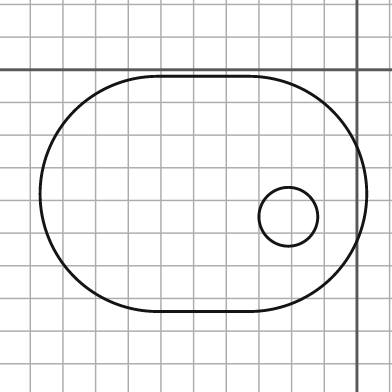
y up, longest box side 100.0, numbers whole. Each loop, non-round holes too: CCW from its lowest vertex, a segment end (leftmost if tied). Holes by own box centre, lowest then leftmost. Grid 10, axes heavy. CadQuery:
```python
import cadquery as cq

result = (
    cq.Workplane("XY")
    .moveTo(-61.0, -74.0)
    .lineTo(-33.0, -74.0)
    .threePointArc((3.0, -38.0), (-33.0, -2.0))
    .lineTo(-61.0, -2.0)
    .threePointArc((-97.0, -38.0), (-61.0, -74.0))
    .close()
    .moveTo(-21.0, -45.0)
    .circle(9.0)
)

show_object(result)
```